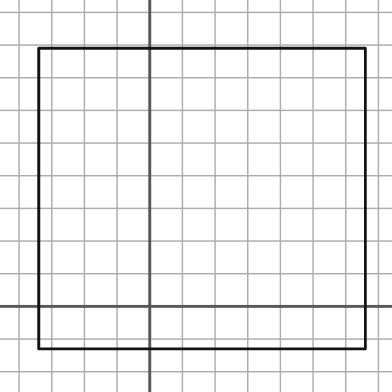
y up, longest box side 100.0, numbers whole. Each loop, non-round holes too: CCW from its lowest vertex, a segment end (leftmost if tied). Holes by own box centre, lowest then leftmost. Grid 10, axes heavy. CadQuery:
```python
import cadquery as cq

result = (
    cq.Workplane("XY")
    .moveTo(-34.0, -13.0)
    .lineTo(66.0, -13.0)
    .lineTo(66.0, 79.0)
    .lineTo(-34.0, 79.0)
    .close()
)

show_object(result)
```